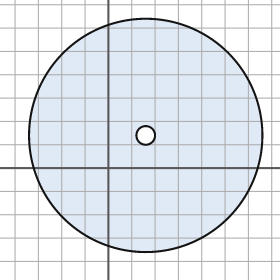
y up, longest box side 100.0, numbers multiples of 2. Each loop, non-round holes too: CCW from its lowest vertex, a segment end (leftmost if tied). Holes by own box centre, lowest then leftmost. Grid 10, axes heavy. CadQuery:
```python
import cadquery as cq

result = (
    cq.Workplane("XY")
    .moveTo(16.0, 14.0)
    .circle(50.0)
    .moveTo(16.0, 14.0)
    .circle(4.0)
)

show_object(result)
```